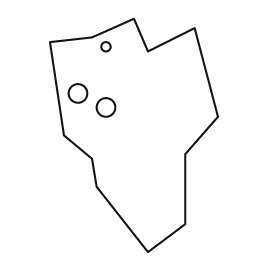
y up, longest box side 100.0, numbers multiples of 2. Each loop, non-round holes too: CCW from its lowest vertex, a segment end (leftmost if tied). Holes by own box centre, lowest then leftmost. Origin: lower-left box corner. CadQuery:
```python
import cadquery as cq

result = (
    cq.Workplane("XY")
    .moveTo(42.0, 0.0)
    .lineTo(58.0, 12.0)
    .lineTo(58.0, 42.0)
    .lineTo(72.0, 58.0)
    .lineTo(62.0, 96.0)
    .lineTo(42.0, 86.0)
    .lineTo(36.0, 100.0)
    .lineTo(18.0, 92.0)
    .lineTo(0.0, 90.0)
    .lineTo(6.0, 50.0)
    .lineTo(18.0, 40.0)
    .lineTo(20.0, 28.0)
    .close()
    .moveTo(24.0, 62.0)
    .circle(4.0)
    .moveTo(12.0, 68.0)
    .circle(4.0)
    .moveTo(24.0, 88.0)
    .circle(2.0)
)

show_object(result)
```